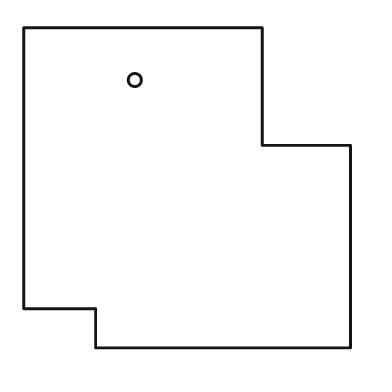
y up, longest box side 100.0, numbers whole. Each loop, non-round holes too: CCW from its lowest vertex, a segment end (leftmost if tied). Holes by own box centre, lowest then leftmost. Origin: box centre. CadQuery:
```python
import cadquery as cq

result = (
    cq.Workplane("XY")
    .moveTo(-28.0, -49.0)
    .lineTo(50.0, -49.0)
    .lineTo(50.0, 13.0)
    .lineTo(23.0, 13.0)
    .lineTo(23.0, 49.0)
    .lineTo(-50.0, 49.0)
    .lineTo(-50.0, -37.0)
    .lineTo(-28.0, -37.0)
    .close()
    .moveTo(-16.0, 33.0)
    .circle(2.0)
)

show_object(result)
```